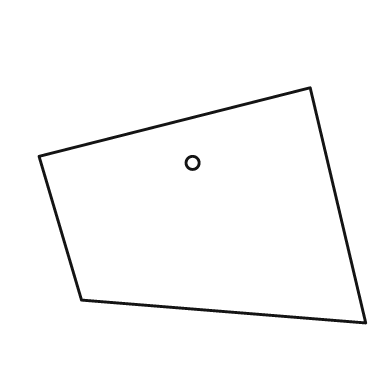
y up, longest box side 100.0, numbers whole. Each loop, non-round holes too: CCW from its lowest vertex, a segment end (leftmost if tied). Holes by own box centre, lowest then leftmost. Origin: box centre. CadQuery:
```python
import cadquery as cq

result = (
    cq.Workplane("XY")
    .moveTo(50.0, -36.0)
    .lineTo(33.0, 36.0)
    .lineTo(-50.0, 15.0)
    .lineTo(-37.0, -29.0)
    .close()
    .moveTo(-3.0, 13.0)
    .circle(2.0)
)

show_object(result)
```